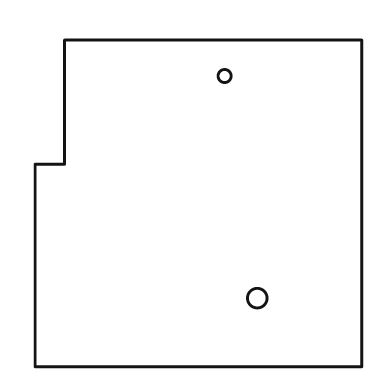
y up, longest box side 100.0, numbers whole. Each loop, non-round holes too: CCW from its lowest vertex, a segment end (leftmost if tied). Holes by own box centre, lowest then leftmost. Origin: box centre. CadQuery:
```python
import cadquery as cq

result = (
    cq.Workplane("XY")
    .moveTo(-50.0, -50.0)
    .lineTo(50.0, -50.0)
    .lineTo(50.0, 50.0)
    .lineTo(-41.0, 50.0)
    .lineTo(-41.0, 12.0)
    .lineTo(-50.0, 12.0)
    .close()
    .moveTo(18.0, -29.0)
    .circle(3.0)
    .moveTo(8.0, 39.0)
    .circle(2.0)
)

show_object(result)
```